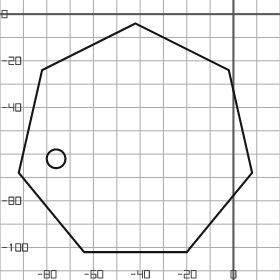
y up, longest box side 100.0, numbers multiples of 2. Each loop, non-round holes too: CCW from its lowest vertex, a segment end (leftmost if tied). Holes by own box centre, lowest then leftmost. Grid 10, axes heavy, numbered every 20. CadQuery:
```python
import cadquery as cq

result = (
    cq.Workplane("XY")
    .moveTo(-64.0, -102.0)
    .lineTo(-20.0, -102.0)
    .lineTo(8.0, -68.0)
    .lineTo(-2.0, -24.0)
    .lineTo(-42.0, -4.0)
    .lineTo(-82.0, -24.0)
    .lineTo(-92.0, -68.0)
    .close()
    .moveTo(-76.0, -62.0)
    .circle(4.0)
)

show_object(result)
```